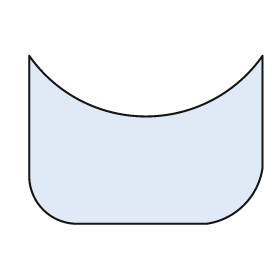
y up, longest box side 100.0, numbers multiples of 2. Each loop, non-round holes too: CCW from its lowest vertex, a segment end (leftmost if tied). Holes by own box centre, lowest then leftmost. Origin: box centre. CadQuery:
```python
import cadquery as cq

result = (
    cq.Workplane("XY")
    .moveTo(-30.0, -36.0)
    .lineTo(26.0, -36.0)
    .threePointArc((42.0, -28.0), (50.0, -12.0))
    .lineTo(50.0, 36.0)
    .threePointArc((0.0, 10.0), (-50.0, 36.0))
    .lineTo(-50.0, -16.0)
    .threePointArc((-44.0, -30.0), (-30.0, -36.0))
    .close()
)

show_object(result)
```